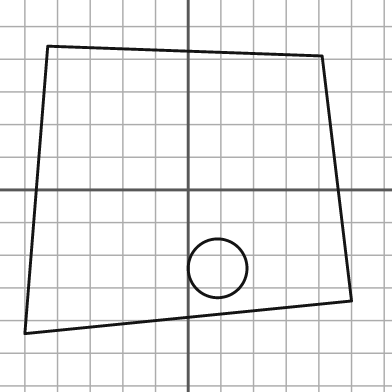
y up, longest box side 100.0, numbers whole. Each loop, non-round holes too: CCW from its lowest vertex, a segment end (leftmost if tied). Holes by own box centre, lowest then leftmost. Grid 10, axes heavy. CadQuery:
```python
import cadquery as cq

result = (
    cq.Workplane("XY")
    .moveTo(-50.0, -44.0)
    .lineTo(50.0, -34.0)
    .lineTo(41.0, 41.0)
    .lineTo(-43.0, 44.0)
    .close()
    .moveTo(9.0, -24.0)
    .circle(9.0)
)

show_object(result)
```